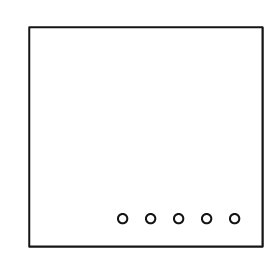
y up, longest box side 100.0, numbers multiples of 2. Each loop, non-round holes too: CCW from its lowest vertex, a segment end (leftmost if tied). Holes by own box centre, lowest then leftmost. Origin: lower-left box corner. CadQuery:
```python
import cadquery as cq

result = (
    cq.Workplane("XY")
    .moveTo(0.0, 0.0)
    .lineTo(100.0, 0.0)
    .lineTo(100.0, 94.0)
    .lineTo(0.0, 94.0)
    .close()
    .moveTo(40.0, 12.0)
    .circle(2.0)
    .moveTo(52.0, 12.0)
    .circle(2.0)
    .moveTo(64.0, 12.0)
    .circle(2.0)
    .moveTo(76.0, 12.0)
    .circle(2.0)
    .moveTo(88.0, 12.0)
    .circle(2.0)
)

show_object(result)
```